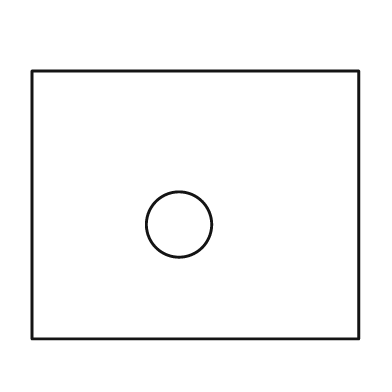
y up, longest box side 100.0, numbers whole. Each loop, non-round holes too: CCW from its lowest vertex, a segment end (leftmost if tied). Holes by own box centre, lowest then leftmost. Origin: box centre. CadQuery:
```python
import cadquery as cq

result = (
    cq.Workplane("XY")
    .moveTo(-50.0, -41.0)
    .lineTo(50.0, -41.0)
    .lineTo(50.0, 41.0)
    .lineTo(-50.0, 41.0)
    .close()
    .moveTo(-5.0, -6.0)
    .circle(10.0)
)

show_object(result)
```